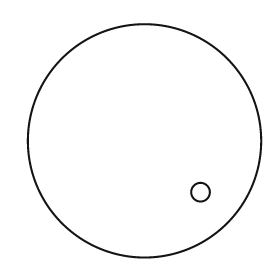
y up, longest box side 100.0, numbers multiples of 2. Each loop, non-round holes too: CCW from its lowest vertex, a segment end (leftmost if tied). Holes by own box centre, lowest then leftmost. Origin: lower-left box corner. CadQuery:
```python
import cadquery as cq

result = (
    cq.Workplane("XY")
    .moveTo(50.0, 50.0)
    .circle(50.0)
    .moveTo(74.0, 28.0)
    .circle(4.0)
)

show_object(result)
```